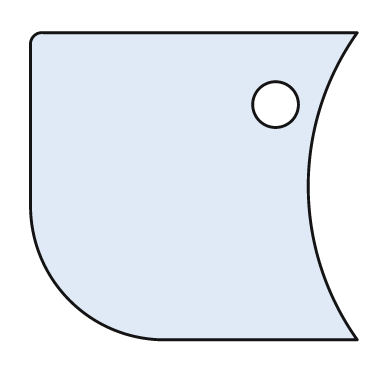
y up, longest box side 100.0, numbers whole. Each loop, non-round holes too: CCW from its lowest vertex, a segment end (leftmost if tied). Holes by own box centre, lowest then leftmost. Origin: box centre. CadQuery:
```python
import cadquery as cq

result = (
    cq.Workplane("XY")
    .moveTo(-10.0, -47.0)
    .lineTo(50.0, -47.0)
    .threePointArc((35.0, 0.0), (50.0, 47.0))
    .lineTo(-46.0, 47.0)
    .threePointArc((-49.0, 46.0), (-50.0, 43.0))
    .lineTo(-50.0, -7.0)
    .threePointArc((-38.0, -35.0), (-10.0, -47.0))
    .close()
    .moveTo(25.0, 25.0)
    .circle(7.0)
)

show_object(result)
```